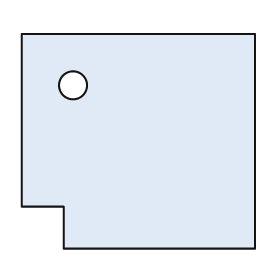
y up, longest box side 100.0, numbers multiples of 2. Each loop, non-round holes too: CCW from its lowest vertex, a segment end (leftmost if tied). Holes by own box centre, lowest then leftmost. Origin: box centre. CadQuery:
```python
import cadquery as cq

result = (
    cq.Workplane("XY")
    .moveTo(-32.0, -46.0)
    .lineTo(50.0, -46.0)
    .lineTo(50.0, 46.0)
    .lineTo(-50.0, 46.0)
    .lineTo(-50.0, -28.0)
    .lineTo(-32.0, -28.0)
    .close()
    .moveTo(-28.0, 24.0)
    .circle(6.0)
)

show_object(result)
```